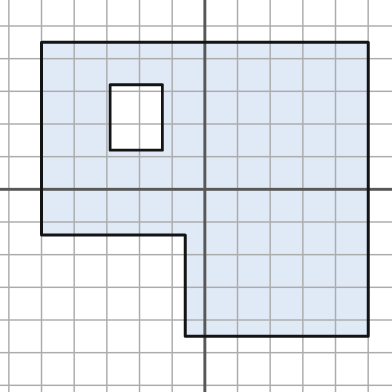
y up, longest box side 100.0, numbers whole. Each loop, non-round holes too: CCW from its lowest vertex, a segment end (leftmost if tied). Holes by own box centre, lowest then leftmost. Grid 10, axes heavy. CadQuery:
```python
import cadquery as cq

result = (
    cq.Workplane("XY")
    .moveTo(-6.0, -45.0)
    .lineTo(50.0, -45.0)
    .lineTo(50.0, 45.0)
    .lineTo(-50.0, 45.0)
    .lineTo(-50.0, -14.0)
    .lineTo(-6.0, -14.0)
    .close()
    .moveTo(-29.0, 12.0)
    .lineTo(-13.0, 12.0)
    .lineTo(-13.0, 32.0)
    .lineTo(-29.0, 32.0)
    .close()
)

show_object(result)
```